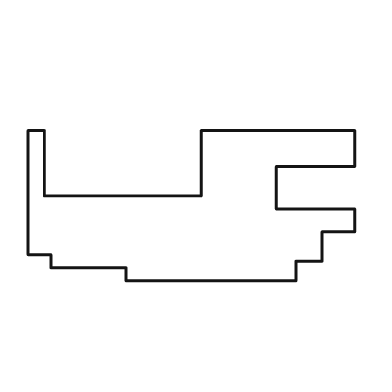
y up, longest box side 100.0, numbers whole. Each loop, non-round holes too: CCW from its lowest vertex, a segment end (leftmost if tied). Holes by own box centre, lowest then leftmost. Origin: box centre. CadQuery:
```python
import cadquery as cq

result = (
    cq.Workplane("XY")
    .moveTo(-20.0, -23.0)
    .lineTo(32.0, -23.0)
    .lineTo(32.0, -17.0)
    .lineTo(40.0, -17.0)
    .lineTo(40.0, -8.0)
    .lineTo(50.0, -8.0)
    .lineTo(50.0, -1.0)
    .lineTo(26.0, -1.0)
    .lineTo(26.0, 12.0)
    .lineTo(50.0, 12.0)
    .lineTo(50.0, 23.0)
    .lineTo(3.0, 23.0)
    .lineTo(3.0, 3.0)
    .lineTo(-45.0, 3.0)
    .lineTo(-45.0, 23.0)
    .lineTo(-50.0, 23.0)
    .lineTo(-50.0, -15.0)
    .lineTo(-43.0, -15.0)
    .lineTo(-43.0, -19.0)
    .lineTo(-20.0, -19.0)
    .close()
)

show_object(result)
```